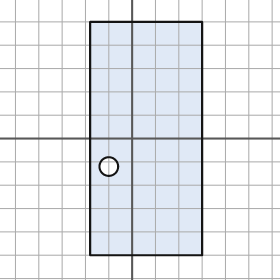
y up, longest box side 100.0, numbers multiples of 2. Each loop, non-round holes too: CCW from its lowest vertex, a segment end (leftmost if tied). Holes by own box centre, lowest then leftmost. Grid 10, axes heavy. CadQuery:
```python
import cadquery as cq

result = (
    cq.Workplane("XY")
    .moveTo(-18.0, -50.0)
    .lineTo(30.0, -50.0)
    .lineTo(30.0, 50.0)
    .lineTo(-18.0, 50.0)
    .close()
    .moveTo(-10.0, -12.0)
    .circle(4.0)
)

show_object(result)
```